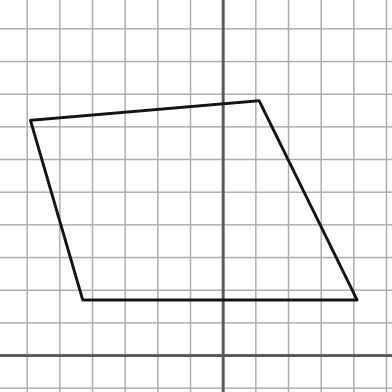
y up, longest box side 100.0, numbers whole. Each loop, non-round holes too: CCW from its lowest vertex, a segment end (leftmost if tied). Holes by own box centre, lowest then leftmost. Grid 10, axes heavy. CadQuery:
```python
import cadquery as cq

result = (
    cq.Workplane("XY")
    .moveTo(-43.0, 17.0)
    .lineTo(41.0, 17.0)
    .lineTo(11.0, 78.0)
    .lineTo(-59.0, 72.0)
    .close()
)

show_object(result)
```